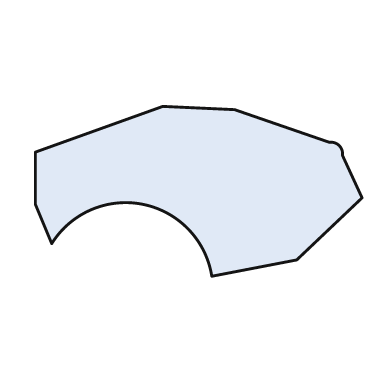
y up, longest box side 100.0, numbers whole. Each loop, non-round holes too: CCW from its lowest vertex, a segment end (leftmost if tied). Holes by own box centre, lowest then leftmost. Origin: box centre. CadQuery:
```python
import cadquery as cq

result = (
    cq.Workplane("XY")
    .moveTo(4.0, -26.0)
    .lineTo(30.0, -21.0)
    .lineTo(50.0, -2.0)
    .lineTo(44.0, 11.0)
    .threePointArc((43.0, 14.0), (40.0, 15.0))
    .lineTo(11.0, 25.0)
    .lineTo(-11.0, 26.0)
    .lineTo(-50.0, 12.0)
    .lineTo(-50.0, -4.0)
    .lineTo(-45.0, -16.0)
    .threePointArc((-17.0, -4.0), (4.0, -26.0))
    .close()
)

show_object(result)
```